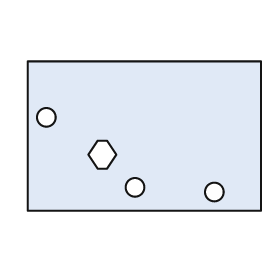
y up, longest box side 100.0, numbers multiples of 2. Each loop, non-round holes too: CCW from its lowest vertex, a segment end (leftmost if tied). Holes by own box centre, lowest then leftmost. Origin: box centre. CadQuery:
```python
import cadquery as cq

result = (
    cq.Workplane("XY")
    .moveTo(-50.0, -32.0)
    .lineTo(50.0, -32.0)
    .lineTo(50.0, 32.0)
    .lineTo(-50.0, 32.0)
    .close()
    .moveTo(30.0, -24.0)
    .circle(4.0)
    .moveTo(-4.0, -22.0)
    .circle(4.0)
    .moveTo(-20.0, -14.0)
    .lineTo(-16.0, -14.0)
    .lineTo(-12.0, -8.0)
    .lineTo(-16.0, -2.0)
    .lineTo(-20.0, -2.0)
    .lineTo(-24.0, -8.0)
    .close()
    .moveTo(-42.0, 8.0)
    .circle(4.0)
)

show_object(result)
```